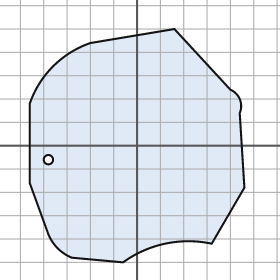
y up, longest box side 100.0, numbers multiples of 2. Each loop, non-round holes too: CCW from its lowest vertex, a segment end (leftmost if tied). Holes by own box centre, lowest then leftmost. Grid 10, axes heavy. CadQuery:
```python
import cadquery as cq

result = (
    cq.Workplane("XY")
    .moveTo(-6.0, -50.0)
    .threePointArc((12.0, -42.0), (32.0, -42.0))
    .lineTo(46.0, -18.0)
    .lineTo(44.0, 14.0)
    .threePointArc((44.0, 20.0), (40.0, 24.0))
    .lineTo(16.0, 50.0)
    .lineTo(-20.0, 44.0)
    .threePointArc((-36.0, 34.0), (-46.0, 18.0))
    .lineTo(-46.0, -16.0)
    .lineTo(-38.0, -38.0)
    .threePointArc((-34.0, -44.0), (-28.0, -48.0))
    .close()
    .moveTo(-38.0, -6.0)
    .circle(2.0)
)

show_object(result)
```